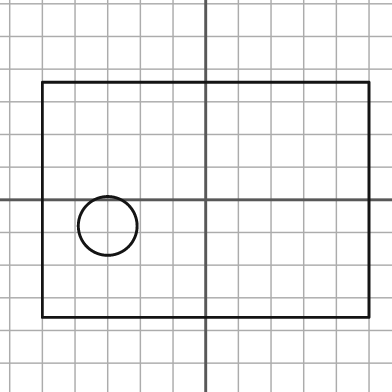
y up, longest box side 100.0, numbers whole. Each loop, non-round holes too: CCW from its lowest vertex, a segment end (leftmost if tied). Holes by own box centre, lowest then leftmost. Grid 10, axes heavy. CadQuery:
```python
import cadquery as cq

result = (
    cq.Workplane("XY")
    .moveTo(-50.0, -36.0)
    .lineTo(50.0, -36.0)
    .lineTo(50.0, 36.0)
    .lineTo(-50.0, 36.0)
    .close()
    .moveTo(-30.0, -8.0)
    .circle(9.0)
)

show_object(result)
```